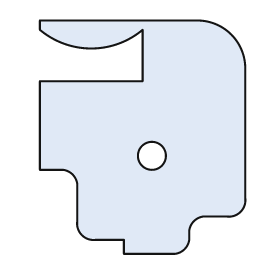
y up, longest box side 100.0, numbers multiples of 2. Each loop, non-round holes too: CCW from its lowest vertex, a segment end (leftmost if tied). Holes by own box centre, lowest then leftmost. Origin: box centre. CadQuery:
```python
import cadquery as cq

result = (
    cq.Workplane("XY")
    .moveTo(-8.0, -50.0)
    .lineTo(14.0, -50.0)
    .threePointArc((18.0, -48.0), (20.0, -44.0))
    .lineTo(20.0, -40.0)
    .threePointArc((22.0, -36.0), (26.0, -34.0))
    .lineTo(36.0, -34.0)
    .threePointArc((42.0, -32.0), (44.0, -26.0))
    .lineTo(44.0, 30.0)
    .threePointArc((38.0, 44.0), (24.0, 50.0))
    .lineTo(-44.0, 50.0)
    .lineTo(-44.0, 46.0)
    .threePointArc((-22.0, 38.0), (0.0, 46.0))
    .lineTo(0.0, 24.0)
    .lineTo(-44.0, 24.0)
    .lineTo(-44.0, -14.0)
    .lineTo(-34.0, -14.0)
    .threePointArc((-30.0, -16.0), (-28.0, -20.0))
    .lineTo(-28.0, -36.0)
    .threePointArc((-26.0, -42.0), (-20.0, -44.0))
    .lineTo(-8.0, -44.0)
    .close()
    .moveTo(4.0, -8.0)
    .circle(6.0)
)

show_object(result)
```